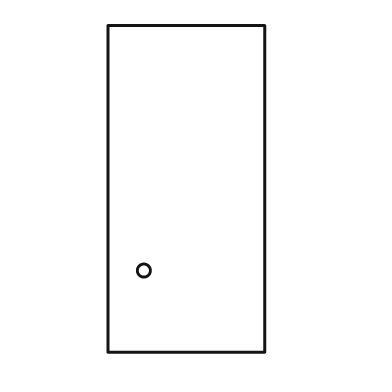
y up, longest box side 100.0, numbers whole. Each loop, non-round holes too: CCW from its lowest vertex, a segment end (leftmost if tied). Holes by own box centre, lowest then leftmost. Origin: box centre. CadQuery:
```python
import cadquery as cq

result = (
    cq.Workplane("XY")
    .moveTo(-24.0, -50.0)
    .lineTo(24.0, -50.0)
    .lineTo(24.0, 50.0)
    .lineTo(-24.0, 50.0)
    .close()
    .moveTo(-13.0, -25.0)
    .circle(2.0)
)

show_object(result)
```